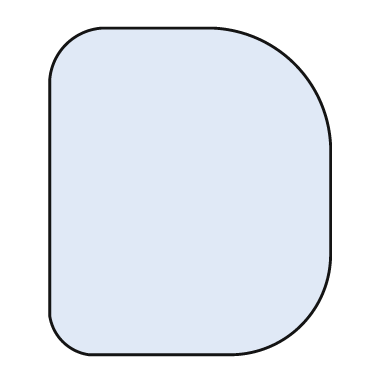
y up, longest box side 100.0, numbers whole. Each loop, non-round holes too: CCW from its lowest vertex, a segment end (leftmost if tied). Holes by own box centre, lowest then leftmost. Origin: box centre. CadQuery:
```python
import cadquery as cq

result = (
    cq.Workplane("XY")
    .moveTo(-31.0, -50.0)
    .lineTo(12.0, -50.0)
    .threePointArc((34.0, -41.0), (43.0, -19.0))
    .lineTo(43.0, 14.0)
    .threePointArc((32.0, 39.0), (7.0, 50.0))
    .lineTo(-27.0, 50.0)
    .threePointArc((-38.0, 45.0), (-43.0, 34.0))
    .lineTo(-43.0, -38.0)
    .threePointArc((-39.0, -46.0), (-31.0, -50.0))
    .close()
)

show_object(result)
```